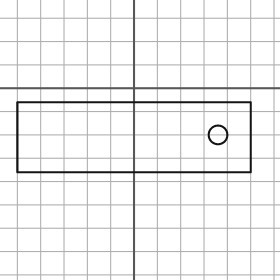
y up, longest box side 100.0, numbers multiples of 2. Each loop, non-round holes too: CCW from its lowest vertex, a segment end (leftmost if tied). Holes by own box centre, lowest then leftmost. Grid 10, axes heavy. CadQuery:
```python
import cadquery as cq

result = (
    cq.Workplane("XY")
    .moveTo(-50.0, -36.0)
    .lineTo(50.0, -36.0)
    .lineTo(50.0, -6.0)
    .lineTo(-50.0, -6.0)
    .close()
    .moveTo(36.0, -20.0)
    .circle(4.0)
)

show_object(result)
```